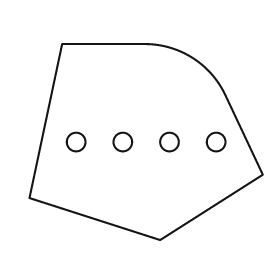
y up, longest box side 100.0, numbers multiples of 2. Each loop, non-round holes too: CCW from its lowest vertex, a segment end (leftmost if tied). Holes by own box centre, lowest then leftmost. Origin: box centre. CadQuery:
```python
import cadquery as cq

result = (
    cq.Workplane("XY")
    .moveTo(6.0, -42.0)
    .lineTo(50.0, -14.0)
    .lineTo(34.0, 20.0)
    .threePointArc((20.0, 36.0), (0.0, 42.0))
    .lineTo(-36.0, 42.0)
    .lineTo(-50.0, -24.0)
    .close()
    .moveTo(-30.0, 0.0)
    .circle(4.0)
    .moveTo(-10.0, 0.0)
    .circle(4.0)
    .moveTo(10.0, 0.0)
    .circle(4.0)
    .moveTo(30.0, 0.0)
    .circle(4.0)
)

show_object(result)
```